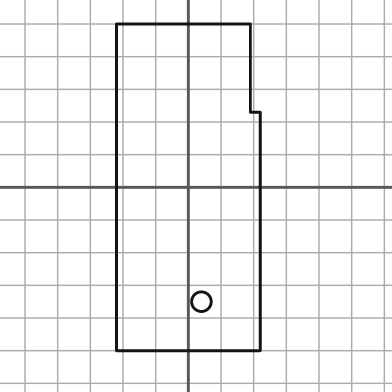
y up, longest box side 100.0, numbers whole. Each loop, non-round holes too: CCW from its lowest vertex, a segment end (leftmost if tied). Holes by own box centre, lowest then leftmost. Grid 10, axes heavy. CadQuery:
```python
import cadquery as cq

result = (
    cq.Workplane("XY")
    .moveTo(-22.0, -50.0)
    .lineTo(22.0, -50.0)
    .lineTo(22.0, 23.0)
    .lineTo(19.0, 23.0)
    .lineTo(19.0, 50.0)
    .lineTo(-22.0, 50.0)
    .close()
    .moveTo(4.0, -35.0)
    .circle(3.0)
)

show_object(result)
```